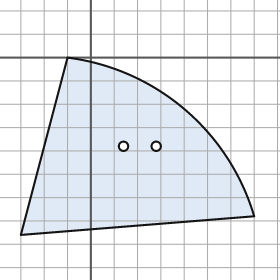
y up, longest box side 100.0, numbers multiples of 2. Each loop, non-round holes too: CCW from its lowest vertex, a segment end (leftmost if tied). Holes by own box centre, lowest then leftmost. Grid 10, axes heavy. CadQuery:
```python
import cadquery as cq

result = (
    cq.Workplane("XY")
    .moveTo(-30.0, -76.0)
    .lineTo(70.0, -68.0)
    .threePointArc((40.0, -22.0), (-10.0, 0.0))
    .close()
    .moveTo(14.0, -38.0)
    .circle(2.0)
    .moveTo(28.0, -38.0)
    .circle(2.0)
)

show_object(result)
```